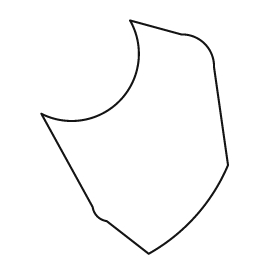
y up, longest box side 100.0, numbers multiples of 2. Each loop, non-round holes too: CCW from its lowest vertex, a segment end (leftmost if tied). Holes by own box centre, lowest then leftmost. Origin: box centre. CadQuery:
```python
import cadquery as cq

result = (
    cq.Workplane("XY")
    .moveTo(6.0, -50.0)
    .threePointArc((26.0, -34.0), (40.0, -12.0))
    .lineTo(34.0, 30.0)
    .threePointArc((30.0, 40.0), (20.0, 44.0))
    .lineTo(-2.0, 50.0)
    .threePointArc((-6.0, 16.0), (-40.0, 10.0))
    .lineTo(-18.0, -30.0)
    .threePointArc((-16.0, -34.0), (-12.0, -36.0))
    .close()
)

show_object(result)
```